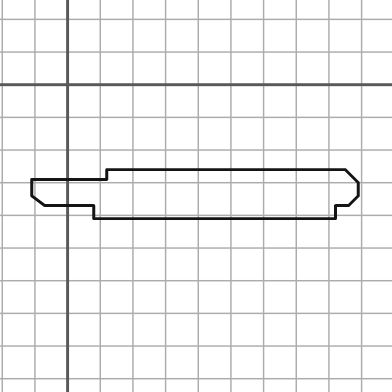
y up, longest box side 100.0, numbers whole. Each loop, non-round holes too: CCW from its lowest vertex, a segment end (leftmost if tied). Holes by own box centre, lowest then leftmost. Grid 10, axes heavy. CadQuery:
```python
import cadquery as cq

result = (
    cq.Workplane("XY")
    .moveTo(8.0, -41.0)
    .lineTo(82.0, -41.0)
    .lineTo(82.0, -37.0)
    .lineTo(86.0, -37.0)
    .lineTo(89.0, -34.0)
    .lineTo(89.0, -30.0)
    .lineTo(85.0, -26.0)
    .lineTo(12.0, -26.0)
    .lineTo(12.0, -29.0)
    .lineTo(-11.0, -29.0)
    .lineTo(-11.0, -34.0)
    .lineTo(-7.0, -37.0)
    .lineTo(8.0, -37.0)
    .close()
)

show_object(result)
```